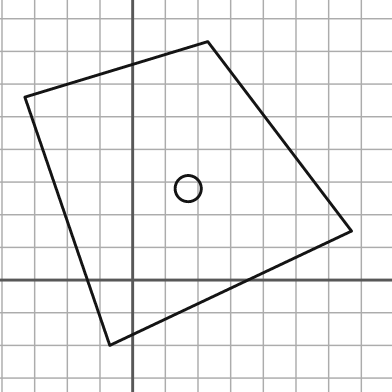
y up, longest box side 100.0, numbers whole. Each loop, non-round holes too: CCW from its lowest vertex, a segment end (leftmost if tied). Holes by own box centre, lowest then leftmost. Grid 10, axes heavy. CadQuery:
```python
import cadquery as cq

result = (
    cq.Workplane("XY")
    .moveTo(-7.0, -20.0)
    .lineTo(67.0, 15.0)
    .lineTo(23.0, 73.0)
    .lineTo(-33.0, 56.0)
    .close()
    .moveTo(17.0, 28.0)
    .circle(4.0)
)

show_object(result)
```